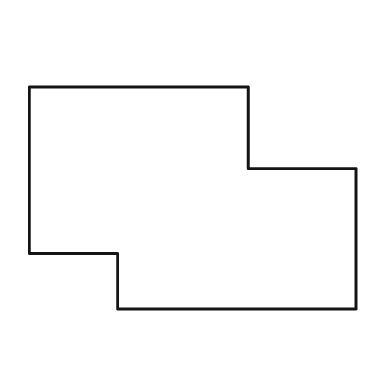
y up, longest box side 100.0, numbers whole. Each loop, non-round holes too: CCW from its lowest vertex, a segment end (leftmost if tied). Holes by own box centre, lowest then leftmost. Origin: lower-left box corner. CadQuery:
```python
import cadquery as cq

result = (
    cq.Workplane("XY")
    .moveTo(27.0, 0.0)
    .lineTo(100.0, 0.0)
    .lineTo(100.0, 43.0)
    .lineTo(67.0, 43.0)
    .lineTo(67.0, 68.0)
    .lineTo(0.0, 68.0)
    .lineTo(0.0, 17.0)
    .lineTo(27.0, 17.0)
    .close()
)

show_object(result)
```